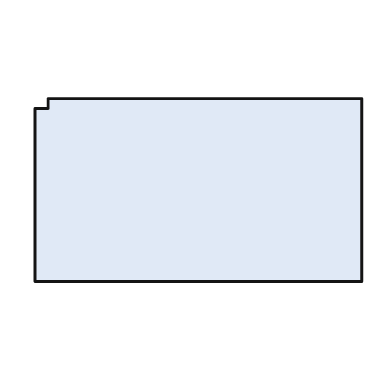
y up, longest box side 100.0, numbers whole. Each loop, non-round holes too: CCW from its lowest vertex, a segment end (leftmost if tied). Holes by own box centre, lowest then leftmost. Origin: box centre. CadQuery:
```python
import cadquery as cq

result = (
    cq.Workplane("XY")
    .moveTo(-50.0, -28.0)
    .lineTo(50.0, -28.0)
    .lineTo(50.0, 28.0)
    .lineTo(-46.0, 28.0)
    .lineTo(-46.0, 25.0)
    .lineTo(-50.0, 25.0)
    .close()
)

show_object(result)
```